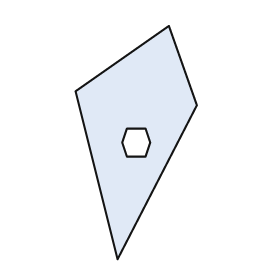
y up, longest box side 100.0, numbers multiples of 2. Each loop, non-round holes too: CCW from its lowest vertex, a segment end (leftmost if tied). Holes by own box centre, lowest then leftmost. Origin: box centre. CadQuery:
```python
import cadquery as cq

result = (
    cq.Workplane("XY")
    .moveTo(-8.0, -50.0)
    .lineTo(26.0, 16.0)
    .lineTo(14.0, 50.0)
    .lineTo(-26.0, 22.0)
    .close()
    .moveTo(-4.0, -6.0)
    .lineTo(4.0, -6.0)
    .lineTo(6.0, 0.0)
    .lineTo(4.0, 6.0)
    .lineTo(-4.0, 6.0)
    .lineTo(-6.0, 0.0)
    .close()
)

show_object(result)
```